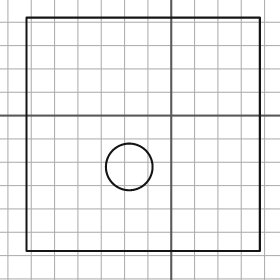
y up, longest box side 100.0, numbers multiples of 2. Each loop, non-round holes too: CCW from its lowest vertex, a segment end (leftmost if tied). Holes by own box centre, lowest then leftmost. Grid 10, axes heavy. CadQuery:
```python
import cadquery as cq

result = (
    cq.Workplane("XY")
    .moveTo(-62.0, -58.0)
    .lineTo(38.0, -58.0)
    .lineTo(38.0, 42.0)
    .lineTo(-62.0, 42.0)
    .close()
    .moveTo(-18.0, -22.0)
    .circle(10.0)
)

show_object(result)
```